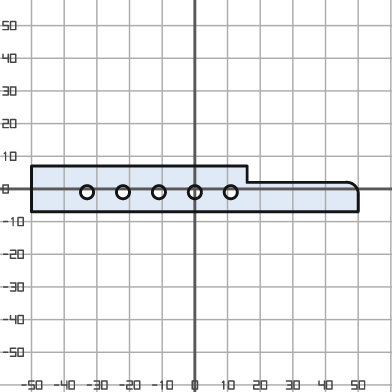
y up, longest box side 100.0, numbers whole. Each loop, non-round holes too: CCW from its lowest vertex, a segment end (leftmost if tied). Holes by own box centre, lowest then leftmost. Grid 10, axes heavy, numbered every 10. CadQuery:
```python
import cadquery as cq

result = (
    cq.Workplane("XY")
    .moveTo(-50.0, -7.0)
    .lineTo(50.0, -7.0)
    .lineTo(50.0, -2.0)
    .threePointArc((49.0, 1.0), (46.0, 2.0))
    .lineTo(16.0, 2.0)
    .lineTo(16.0, 7.0)
    .lineTo(-50.0, 7.0)
    .close()
    .moveTo(-33.0, -1.0)
    .circle(2.0)
    .moveTo(-22.0, -1.0)
    .circle(2.0)
    .moveTo(-11.0, -1.0)
    .circle(2.0)
    .moveTo(0.0, -1.0)
    .circle(2.0)
    .moveTo(11.0, -1.0)
    .circle(2.0)
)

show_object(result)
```